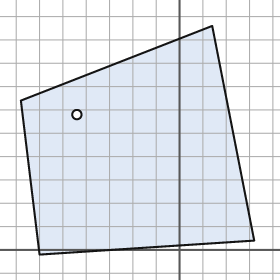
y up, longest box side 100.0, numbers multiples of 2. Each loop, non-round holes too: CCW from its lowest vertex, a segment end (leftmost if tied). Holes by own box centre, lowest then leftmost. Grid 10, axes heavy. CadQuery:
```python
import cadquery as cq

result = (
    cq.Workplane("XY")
    .moveTo(-60.0, -2.0)
    .lineTo(32.0, 4.0)
    .lineTo(14.0, 96.0)
    .lineTo(-68.0, 64.0)
    .close()
    .moveTo(-44.0, 58.0)
    .circle(2.0)
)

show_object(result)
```